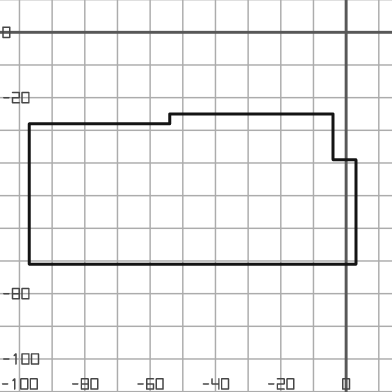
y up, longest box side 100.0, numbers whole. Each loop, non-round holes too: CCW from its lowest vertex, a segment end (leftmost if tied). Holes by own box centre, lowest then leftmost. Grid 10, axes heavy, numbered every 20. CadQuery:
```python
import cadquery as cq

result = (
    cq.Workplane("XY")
    .moveTo(-97.0, -71.0)
    .lineTo(3.0, -71.0)
    .lineTo(3.0, -39.0)
    .lineTo(-4.0, -39.0)
    .lineTo(-4.0, -25.0)
    .lineTo(-54.0, -25.0)
    .lineTo(-54.0, -28.0)
    .lineTo(-97.0, -28.0)
    .close()
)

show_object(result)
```